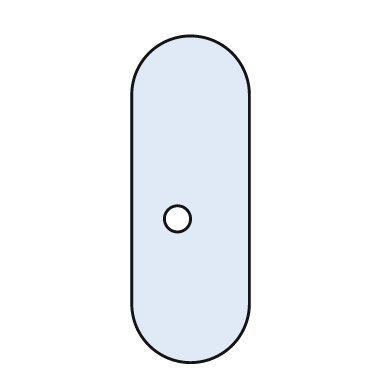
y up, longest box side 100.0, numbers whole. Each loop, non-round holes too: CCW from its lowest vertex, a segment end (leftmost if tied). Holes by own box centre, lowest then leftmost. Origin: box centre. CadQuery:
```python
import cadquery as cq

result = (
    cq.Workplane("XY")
    .moveTo(-18.0, -32.0)
    .threePointArc((0.0, -50.0), (18.0, -32.0))
    .lineTo(18.0, 32.0)
    .threePointArc((0.0, 50.0), (-18.0, 32.0))
    .close()
    .moveTo(-4.0, -6.0)
    .circle(4.0)
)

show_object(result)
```